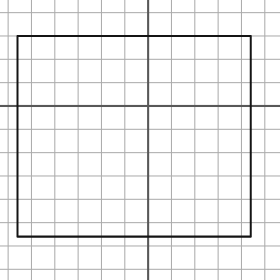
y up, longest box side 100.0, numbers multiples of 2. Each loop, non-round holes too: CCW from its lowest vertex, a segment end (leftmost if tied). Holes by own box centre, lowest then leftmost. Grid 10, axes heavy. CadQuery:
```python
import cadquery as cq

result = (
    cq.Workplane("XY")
    .moveTo(-56.0, -56.0)
    .lineTo(44.0, -56.0)
    .lineTo(44.0, 30.0)
    .lineTo(-56.0, 30.0)
    .close()
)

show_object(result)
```